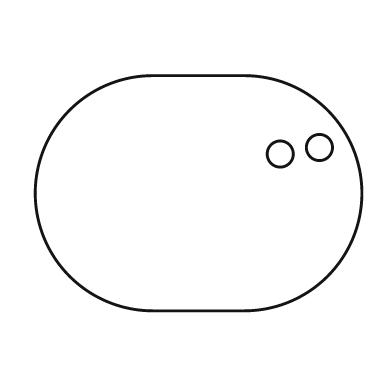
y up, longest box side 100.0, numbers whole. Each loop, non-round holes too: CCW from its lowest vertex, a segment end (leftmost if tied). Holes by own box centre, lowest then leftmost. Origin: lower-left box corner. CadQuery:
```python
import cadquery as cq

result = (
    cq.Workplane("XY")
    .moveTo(36.0, 0.0)
    .lineTo(64.0, 0.0)
    .threePointArc((100.0, 36.0), (64.0, 72.0))
    .lineTo(36.0, 72.0)
    .threePointArc((0.0, 36.0), (36.0, 0.0))
    .close()
    .moveTo(75.0, 48.0)
    .circle(4.0)
    .moveTo(87.0, 50.0)
    .circle(4.0)
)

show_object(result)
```